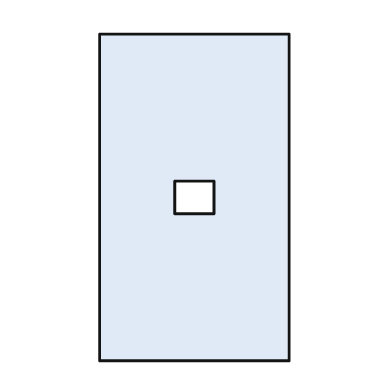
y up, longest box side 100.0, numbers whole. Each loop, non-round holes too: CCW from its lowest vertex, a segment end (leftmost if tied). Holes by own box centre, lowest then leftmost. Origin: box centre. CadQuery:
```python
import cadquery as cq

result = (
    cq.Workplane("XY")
    .moveTo(-29.0, -50.0)
    .lineTo(29.0, -50.0)
    .lineTo(29.0, 50.0)
    .lineTo(-29.0, 50.0)
    .close()
    .moveTo(-6.0, -5.0)
    .lineTo(6.0, -5.0)
    .lineTo(6.0, 5.0)
    .lineTo(-6.0, 5.0)
    .close()
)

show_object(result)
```